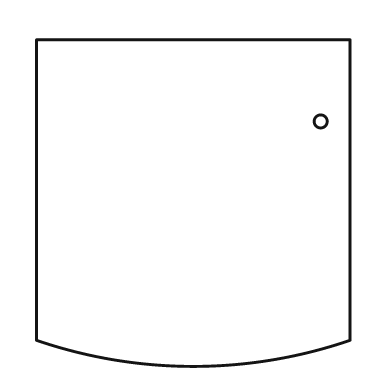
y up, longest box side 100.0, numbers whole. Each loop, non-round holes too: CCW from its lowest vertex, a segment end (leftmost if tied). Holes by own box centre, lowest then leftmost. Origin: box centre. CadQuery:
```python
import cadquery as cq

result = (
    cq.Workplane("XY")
    .moveTo(-48.0, -42.0)
    .threePointArc((0.0, -50.0), (48.0, -42.0))
    .lineTo(48.0, 50.0)
    .lineTo(-48.0, 50.0)
    .close()
    .moveTo(39.0, 25.0)
    .circle(2.0)
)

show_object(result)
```